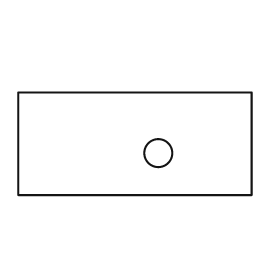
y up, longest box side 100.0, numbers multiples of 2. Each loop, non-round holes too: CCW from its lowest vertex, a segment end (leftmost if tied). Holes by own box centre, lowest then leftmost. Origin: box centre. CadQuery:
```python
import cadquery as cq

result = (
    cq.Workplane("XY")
    .moveTo(-50.0, -22.0)
    .lineTo(50.0, -22.0)
    .lineTo(50.0, 22.0)
    .lineTo(-50.0, 22.0)
    .close()
    .moveTo(10.0, -4.0)
    .circle(6.0)
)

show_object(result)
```